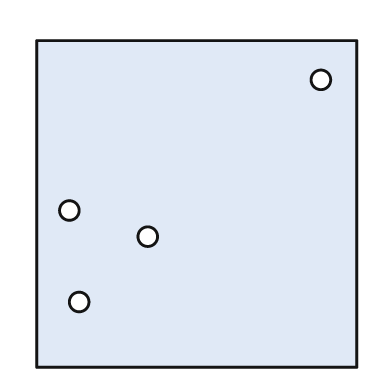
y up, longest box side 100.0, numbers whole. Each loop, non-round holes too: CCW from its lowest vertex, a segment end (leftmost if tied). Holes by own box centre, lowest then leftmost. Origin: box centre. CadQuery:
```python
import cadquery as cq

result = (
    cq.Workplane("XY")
    .moveTo(-49.0, -50.0)
    .lineTo(49.0, -50.0)
    .lineTo(49.0, 50.0)
    .lineTo(-49.0, 50.0)
    .close()
    .moveTo(-36.0, -30.0)
    .circle(3.0)
    .moveTo(-15.0, -10.0)
    .circle(3.0)
    .moveTo(-39.0, -2.0)
    .circle(3.0)
    .moveTo(38.0, 38.0)
    .circle(3.0)
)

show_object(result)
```